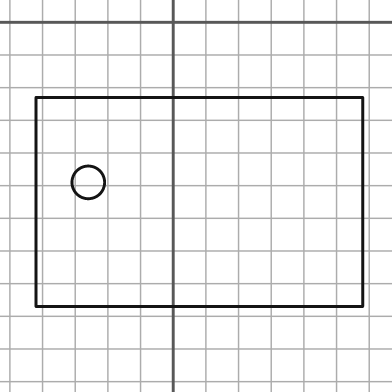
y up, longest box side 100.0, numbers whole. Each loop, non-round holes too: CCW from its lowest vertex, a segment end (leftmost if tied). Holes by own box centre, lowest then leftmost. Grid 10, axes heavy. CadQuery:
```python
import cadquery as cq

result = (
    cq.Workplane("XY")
    .moveTo(-42.0, -87.0)
    .lineTo(58.0, -87.0)
    .lineTo(58.0, -23.0)
    .lineTo(-42.0, -23.0)
    .close()
    .moveTo(-26.0, -49.0)
    .circle(5.0)
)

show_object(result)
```